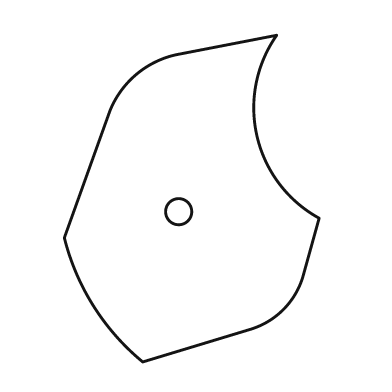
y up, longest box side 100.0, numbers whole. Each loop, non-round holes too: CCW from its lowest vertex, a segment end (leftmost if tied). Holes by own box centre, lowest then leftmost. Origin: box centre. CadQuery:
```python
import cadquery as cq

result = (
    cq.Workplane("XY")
    .moveTo(-15.0, -50.0)
    .lineTo(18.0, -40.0)
    .threePointArc((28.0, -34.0), (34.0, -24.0))
    .lineTo(39.0, -6.0)
    .threePointArc((20.0, 19.0), (26.0, 50.0))
    .lineTo(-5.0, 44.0)
    .threePointArc((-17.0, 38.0), (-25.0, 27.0))
    .lineTo(-39.0, -12.0)
    .threePointArc((-30.0, -33.0), (-15.0, -50.0))
    .close()
    .moveTo(-4.0, -4.0)
    .circle(4.0)
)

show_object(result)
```